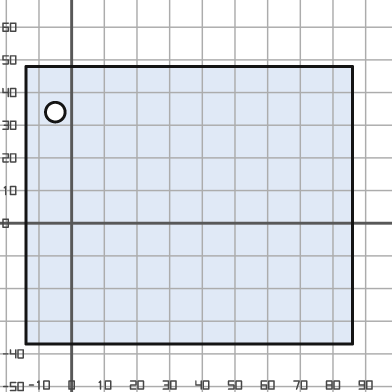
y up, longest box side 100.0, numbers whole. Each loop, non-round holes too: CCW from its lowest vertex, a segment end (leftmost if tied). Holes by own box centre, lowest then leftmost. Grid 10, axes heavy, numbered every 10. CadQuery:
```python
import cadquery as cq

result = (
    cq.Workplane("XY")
    .moveTo(-14.0, -37.0)
    .lineTo(86.0, -37.0)
    .lineTo(86.0, 48.0)
    .lineTo(-14.0, 48.0)
    .close()
    .moveTo(-5.0, 34.0)
    .circle(3.0)
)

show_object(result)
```